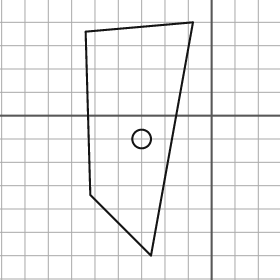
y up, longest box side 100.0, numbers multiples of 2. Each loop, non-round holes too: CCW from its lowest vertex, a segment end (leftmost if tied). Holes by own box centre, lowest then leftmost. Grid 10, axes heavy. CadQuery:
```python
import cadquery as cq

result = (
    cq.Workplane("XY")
    .moveTo(-26.0, -60.0)
    .lineTo(-8.0, 40.0)
    .lineTo(-54.0, 36.0)
    .lineTo(-52.0, -34.0)
    .close()
    .moveTo(-30.0, -10.0)
    .circle(4.0)
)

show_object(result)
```